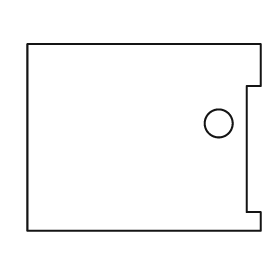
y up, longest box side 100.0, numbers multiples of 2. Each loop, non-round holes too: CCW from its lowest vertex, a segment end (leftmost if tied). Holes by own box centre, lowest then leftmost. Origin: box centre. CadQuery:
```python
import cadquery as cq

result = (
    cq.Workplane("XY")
    .moveTo(-50.0, -40.0)
    .lineTo(50.0, -40.0)
    .lineTo(50.0, -32.0)
    .lineTo(44.0, -32.0)
    .lineTo(44.0, 22.0)
    .lineTo(50.0, 22.0)
    .lineTo(50.0, 40.0)
    .lineTo(-50.0, 40.0)
    .close()
    .moveTo(32.0, 6.0)
    .circle(6.0)
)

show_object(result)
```